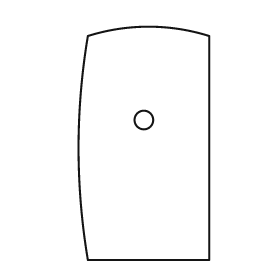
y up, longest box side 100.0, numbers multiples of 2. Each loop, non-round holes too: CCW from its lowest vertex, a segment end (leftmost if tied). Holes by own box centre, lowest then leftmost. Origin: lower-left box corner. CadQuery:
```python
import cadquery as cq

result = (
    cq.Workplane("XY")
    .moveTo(4.0, 0.0)
    .lineTo(56.0, 0.0)
    .lineTo(56.0, 96.0)
    .threePointArc((30.0, 100.0), (4.0, 96.0))
    .threePointArc((0.0, 48.0), (4.0, 0.0))
    .close()
    .moveTo(28.0, 60.0)
    .circle(4.0)
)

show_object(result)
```